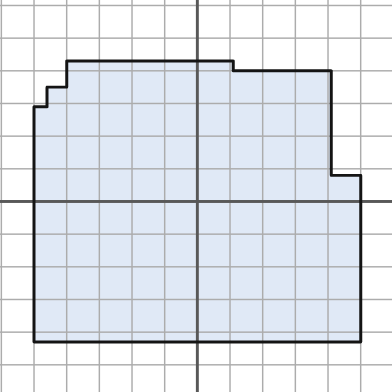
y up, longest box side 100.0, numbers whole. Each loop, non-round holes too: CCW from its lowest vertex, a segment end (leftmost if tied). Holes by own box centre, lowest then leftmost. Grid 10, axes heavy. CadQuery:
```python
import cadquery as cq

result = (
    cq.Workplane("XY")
    .moveTo(-50.0, -43.0)
    .lineTo(50.0, -43.0)
    .lineTo(50.0, 8.0)
    .lineTo(41.0, 8.0)
    .lineTo(41.0, 40.0)
    .lineTo(11.0, 40.0)
    .lineTo(11.0, 43.0)
    .lineTo(-40.0, 43.0)
    .lineTo(-40.0, 35.0)
    .lineTo(-46.0, 35.0)
    .lineTo(-46.0, 29.0)
    .lineTo(-50.0, 29.0)
    .close()
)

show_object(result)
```